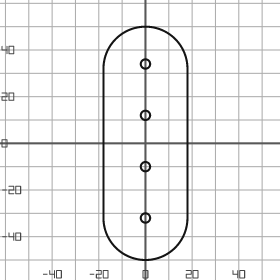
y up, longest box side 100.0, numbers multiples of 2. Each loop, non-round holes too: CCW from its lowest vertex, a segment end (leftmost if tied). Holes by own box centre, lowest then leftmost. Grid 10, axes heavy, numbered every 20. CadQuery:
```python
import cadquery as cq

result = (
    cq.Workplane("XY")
    .moveTo(-18.0, -32.0)
    .threePointArc((0.0, -50.0), (18.0, -32.0))
    .lineTo(18.0, 32.0)
    .threePointArc((0.0, 50.0), (-18.0, 32.0))
    .close()
    .moveTo(0.0, -32.0)
    .circle(2.0)
    .moveTo(0.0, -10.0)
    .circle(2.0)
    .moveTo(0.0, 12.0)
    .circle(2.0)
    .moveTo(0.0, 34.0)
    .circle(2.0)
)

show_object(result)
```